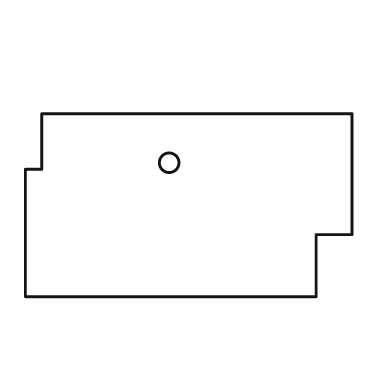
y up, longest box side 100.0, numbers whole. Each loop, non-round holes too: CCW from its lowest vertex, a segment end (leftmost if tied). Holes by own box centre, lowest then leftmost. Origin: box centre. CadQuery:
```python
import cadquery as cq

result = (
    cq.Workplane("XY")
    .moveTo(-50.0, -28.0)
    .lineTo(39.0, -28.0)
    .lineTo(39.0, -9.0)
    .lineTo(50.0, -9.0)
    .lineTo(50.0, 28.0)
    .lineTo(-45.0, 28.0)
    .lineTo(-45.0, 11.0)
    .lineTo(-50.0, 11.0)
    .close()
    .moveTo(-6.0, 13.0)
    .circle(3.0)
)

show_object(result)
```